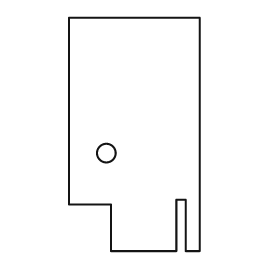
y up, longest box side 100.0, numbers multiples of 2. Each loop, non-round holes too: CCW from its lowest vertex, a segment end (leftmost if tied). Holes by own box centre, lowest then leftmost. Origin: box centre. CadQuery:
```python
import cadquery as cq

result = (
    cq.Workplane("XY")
    .moveTo(-10.0, -50.0)
    .lineTo(18.0, -50.0)
    .lineTo(18.0, -28.0)
    .lineTo(22.0, -28.0)
    .lineTo(22.0, -50.0)
    .lineTo(28.0, -50.0)
    .lineTo(28.0, 50.0)
    .lineTo(-28.0, 50.0)
    .lineTo(-28.0, -30.0)
    .lineTo(-10.0, -30.0)
    .close()
    .moveTo(-12.0, -8.0)
    .circle(4.0)
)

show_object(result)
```